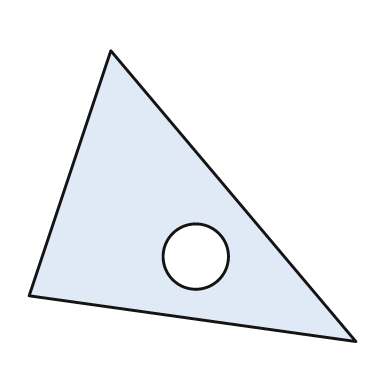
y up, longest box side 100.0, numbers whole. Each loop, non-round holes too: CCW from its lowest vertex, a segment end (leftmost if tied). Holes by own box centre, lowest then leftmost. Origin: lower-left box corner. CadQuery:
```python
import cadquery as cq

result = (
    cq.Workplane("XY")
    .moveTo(100.0, 0.0)
    .lineTo(25.0, 89.0)
    .lineTo(0.0, 14.0)
    .close()
    .moveTo(51.0, 26.0)
    .circle(10.0)
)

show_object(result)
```